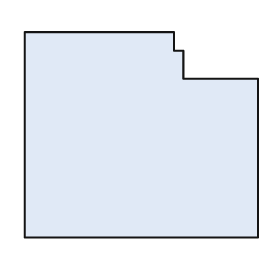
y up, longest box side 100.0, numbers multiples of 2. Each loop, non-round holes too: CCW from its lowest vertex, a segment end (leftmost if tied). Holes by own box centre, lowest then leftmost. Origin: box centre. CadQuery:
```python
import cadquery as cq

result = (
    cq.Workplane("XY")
    .moveTo(-50.0, -44.0)
    .lineTo(50.0, -44.0)
    .lineTo(50.0, 24.0)
    .lineTo(18.0, 24.0)
    .lineTo(18.0, 36.0)
    .lineTo(14.0, 36.0)
    .lineTo(14.0, 44.0)
    .lineTo(-50.0, 44.0)
    .close()
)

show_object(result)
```